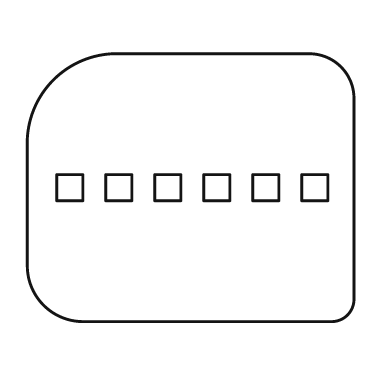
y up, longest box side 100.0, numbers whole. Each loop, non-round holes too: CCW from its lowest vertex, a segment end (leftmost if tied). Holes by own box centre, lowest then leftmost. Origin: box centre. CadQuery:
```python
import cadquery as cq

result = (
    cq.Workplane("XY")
    .moveTo(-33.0, -41.0)
    .lineTo(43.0, -41.0)
    .threePointArc((48.0, -39.0), (50.0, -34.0))
    .lineTo(50.0, 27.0)
    .threePointArc((46.0, 37.0), (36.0, 41.0))
    .lineTo(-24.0, 41.0)
    .threePointArc((-42.0, 33.0), (-50.0, 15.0))
    .lineTo(-50.0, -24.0)
    .threePointArc((-45.0, -36.0), (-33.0, -41.0))
    .close()
    .moveTo(-41.0, -4.0)
    .lineTo(-33.0, -4.0)
    .lineTo(-33.0, 4.0)
    .lineTo(-41.0, 4.0)
    .close()
    .moveTo(-26.0, -4.0)
    .lineTo(-18.0, -4.0)
    .lineTo(-18.0, 4.0)
    .lineTo(-26.0, 4.0)
    .close()
    .moveTo(-11.0, -4.0)
    .lineTo(-3.0, -4.0)
    .lineTo(-3.0, 4.0)
    .lineTo(-11.0, 4.0)
    .close()
    .moveTo(4.0, -4.0)
    .lineTo(12.0, -4.0)
    .lineTo(12.0, 4.0)
    .lineTo(4.0, 4.0)
    .close()
    .moveTo(19.0, -4.0)
    .lineTo(27.0, -4.0)
    .lineTo(27.0, 4.0)
    .lineTo(19.0, 4.0)
    .close()
    .moveTo(34.0, -4.0)
    .lineTo(42.0, -4.0)
    .lineTo(42.0, 4.0)
    .lineTo(34.0, 4.0)
    .close()
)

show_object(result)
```